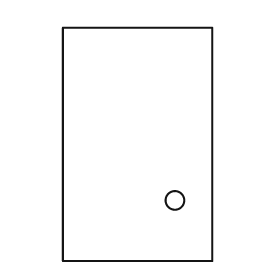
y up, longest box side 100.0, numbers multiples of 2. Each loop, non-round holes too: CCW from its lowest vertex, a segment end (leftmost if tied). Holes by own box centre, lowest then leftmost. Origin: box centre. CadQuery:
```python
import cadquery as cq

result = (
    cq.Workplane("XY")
    .moveTo(-32.0, -50.0)
    .lineTo(32.0, -50.0)
    .lineTo(32.0, 50.0)
    .lineTo(-32.0, 50.0)
    .close()
    .moveTo(16.0, -24.0)
    .circle(4.0)
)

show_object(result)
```